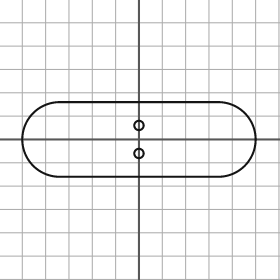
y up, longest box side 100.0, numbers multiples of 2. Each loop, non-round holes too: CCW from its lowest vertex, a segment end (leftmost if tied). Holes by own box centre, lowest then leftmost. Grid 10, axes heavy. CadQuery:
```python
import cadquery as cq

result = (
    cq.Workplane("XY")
    .moveTo(-34.0, -16.0)
    .lineTo(34.0, -16.0)
    .threePointArc((50.0, 0.0), (34.0, 16.0))
    .lineTo(-34.0, 16.0)
    .threePointArc((-50.0, 0.0), (-34.0, -16.0))
    .close()
    .moveTo(0.0, -6.0)
    .circle(2.0)
    .moveTo(0.0, 6.0)
    .circle(2.0)
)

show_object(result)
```